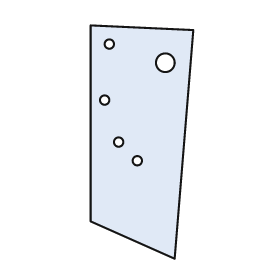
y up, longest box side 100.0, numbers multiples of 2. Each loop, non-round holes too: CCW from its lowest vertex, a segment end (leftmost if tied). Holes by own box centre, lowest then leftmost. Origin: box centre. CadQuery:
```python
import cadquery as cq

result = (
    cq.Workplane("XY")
    .moveTo(14.0, -50.0)
    .lineTo(22.0, 48.0)
    .lineTo(-22.0, 50.0)
    .lineTo(-22.0, -34.0)
    .close()
    .moveTo(-2.0, -8.0)
    .circle(2.0)
    .moveTo(-10.0, 0.0)
    .circle(2.0)
    .moveTo(-16.0, 18.0)
    .circle(2.0)
    .moveTo(10.0, 34.0)
    .circle(4.0)
    .moveTo(-14.0, 42.0)
    .circle(2.0)
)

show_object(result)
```